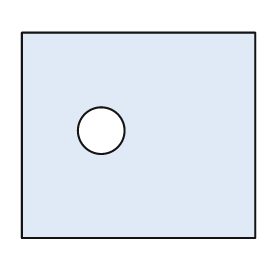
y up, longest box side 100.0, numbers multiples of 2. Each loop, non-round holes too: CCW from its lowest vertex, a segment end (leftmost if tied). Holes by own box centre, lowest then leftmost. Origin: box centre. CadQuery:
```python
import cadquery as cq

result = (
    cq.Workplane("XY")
    .moveTo(-50.0, -44.0)
    .lineTo(50.0, -44.0)
    .lineTo(50.0, 44.0)
    .lineTo(-50.0, 44.0)
    .close()
    .moveTo(-16.0, 2.0)
    .circle(10.0)
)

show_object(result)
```